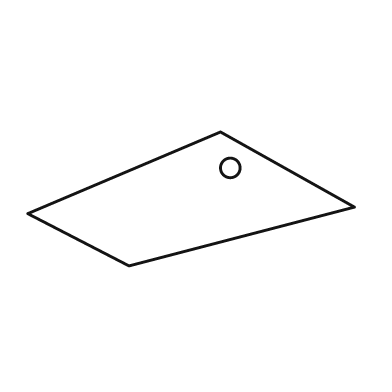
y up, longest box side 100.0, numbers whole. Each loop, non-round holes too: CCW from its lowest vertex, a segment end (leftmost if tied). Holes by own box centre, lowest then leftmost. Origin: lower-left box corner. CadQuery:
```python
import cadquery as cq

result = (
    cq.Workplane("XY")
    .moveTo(31.0, 0.0)
    .lineTo(100.0, 18.0)
    .lineTo(59.0, 41.0)
    .lineTo(0.0, 16.0)
    .close()
    .moveTo(62.0, 30.0)
    .circle(3.0)
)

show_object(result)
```